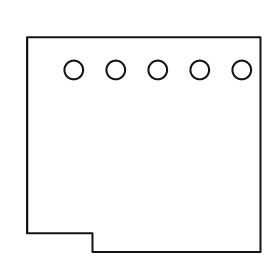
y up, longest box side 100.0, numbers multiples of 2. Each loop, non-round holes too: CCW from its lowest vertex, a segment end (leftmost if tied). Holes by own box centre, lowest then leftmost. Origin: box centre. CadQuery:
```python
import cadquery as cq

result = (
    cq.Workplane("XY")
    .moveTo(-22.0, -46.0)
    .lineTo(50.0, -46.0)
    .lineTo(50.0, 46.0)
    .lineTo(-50.0, 46.0)
    .lineTo(-50.0, -38.0)
    .lineTo(-22.0, -38.0)
    .close()
    .moveTo(-30.0, 32.0)
    .circle(4.0)
    .moveTo(-12.0, 32.0)
    .circle(4.0)
    .moveTo(6.0, 32.0)
    .circle(4.0)
    .moveTo(24.0, 32.0)
    .circle(4.0)
    .moveTo(42.0, 32.0)
    .circle(4.0)
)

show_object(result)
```